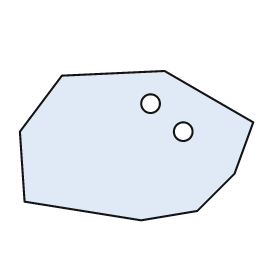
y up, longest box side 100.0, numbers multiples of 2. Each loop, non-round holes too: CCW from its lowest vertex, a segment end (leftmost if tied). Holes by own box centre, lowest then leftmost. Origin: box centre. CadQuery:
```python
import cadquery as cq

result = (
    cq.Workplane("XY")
    .moveTo(2.0, -32.0)
    .lineTo(26.0, -28.0)
    .lineTo(42.0, -12.0)
    .lineTo(50.0, 10.0)
    .lineTo(12.0, 32.0)
    .lineTo(-32.0, 30.0)
    .lineTo(-50.0, 6.0)
    .lineTo(-48.0, -24.0)
    .close()
    .moveTo(20.0, 6.0)
    .circle(4.0)
    .moveTo(6.0, 18.0)
    .circle(4.0)
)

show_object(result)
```